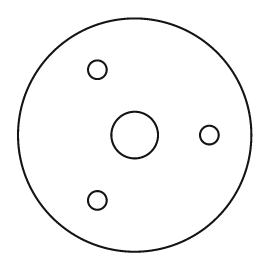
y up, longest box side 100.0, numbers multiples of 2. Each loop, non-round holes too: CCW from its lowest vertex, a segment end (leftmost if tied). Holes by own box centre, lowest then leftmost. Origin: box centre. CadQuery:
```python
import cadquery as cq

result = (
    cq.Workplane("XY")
    .moveTo(0.0, 0.0)
    .circle(50.0)
    .moveTo(-16.0, -28.0)
    .circle(4.0)
    .moveTo(0.0, 0.0)
    .circle(10.0)
    .moveTo(32.0, 0.0)
    .circle(4.0)
    .moveTo(-16.0, 28.0)
    .circle(4.0)
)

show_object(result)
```